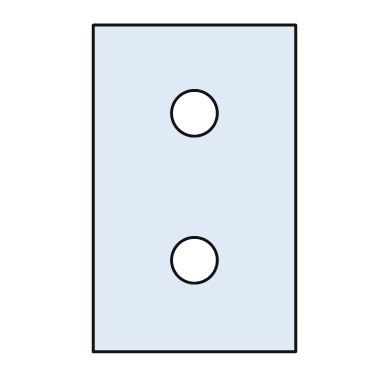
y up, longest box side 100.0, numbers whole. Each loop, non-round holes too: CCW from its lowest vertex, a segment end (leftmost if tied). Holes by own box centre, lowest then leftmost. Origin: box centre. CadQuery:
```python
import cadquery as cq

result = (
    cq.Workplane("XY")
    .moveTo(-31.0, -50.0)
    .lineTo(31.0, -50.0)
    .lineTo(31.0, 50.0)
    .lineTo(-31.0, 50.0)
    .close()
    .moveTo(0.0, -22.0)
    .circle(7.0)
    .moveTo(0.0, 23.0)
    .circle(7.0)
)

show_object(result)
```